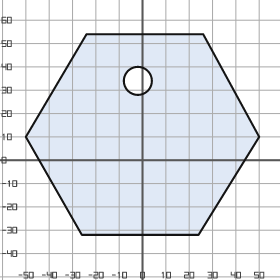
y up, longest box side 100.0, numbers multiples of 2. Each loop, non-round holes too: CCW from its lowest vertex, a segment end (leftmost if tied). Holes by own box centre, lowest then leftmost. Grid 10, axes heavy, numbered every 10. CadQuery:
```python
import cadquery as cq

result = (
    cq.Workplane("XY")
    .moveTo(-26.0, -32.0)
    .lineTo(24.0, -32.0)
    .lineTo(50.0, 10.0)
    .lineTo(26.0, 54.0)
    .lineTo(-24.0, 54.0)
    .lineTo(-50.0, 10.0)
    .close()
    .moveTo(-2.0, 34.0)
    .circle(6.0)
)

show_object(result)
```